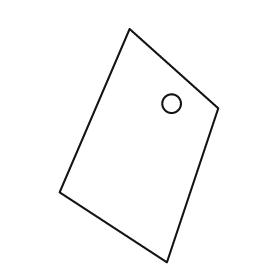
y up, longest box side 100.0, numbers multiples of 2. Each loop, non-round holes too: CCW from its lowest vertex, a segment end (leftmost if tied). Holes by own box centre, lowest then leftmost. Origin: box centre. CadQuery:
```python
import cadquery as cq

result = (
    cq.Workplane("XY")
    .moveTo(12.0, -50.0)
    .lineTo(34.0, 16.0)
    .lineTo(-4.0, 50.0)
    .lineTo(-34.0, -20.0)
    .close()
    .moveTo(14.0, 18.0)
    .circle(4.0)
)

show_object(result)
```